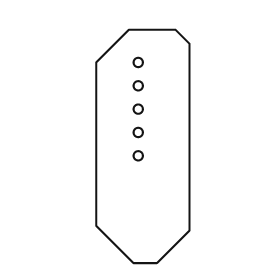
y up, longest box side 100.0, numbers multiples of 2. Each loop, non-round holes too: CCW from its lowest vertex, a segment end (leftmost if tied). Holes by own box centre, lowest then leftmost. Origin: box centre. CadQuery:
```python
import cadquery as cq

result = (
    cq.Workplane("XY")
    .moveTo(-4.0, -50.0)
    .lineTo(6.0, -50.0)
    .lineTo(20.0, -36.0)
    .lineTo(20.0, 44.0)
    .lineTo(14.0, 50.0)
    .lineTo(-6.0, 50.0)
    .lineTo(-20.0, 36.0)
    .lineTo(-20.0, -34.0)
    .close()
    .moveTo(-2.0, -4.0)
    .circle(2.0)
    .moveTo(-2.0, 6.0)
    .circle(2.0)
    .moveTo(-2.0, 16.0)
    .circle(2.0)
    .moveTo(-2.0, 26.0)
    .circle(2.0)
    .moveTo(-2.0, 36.0)
    .circle(2.0)
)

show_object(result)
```